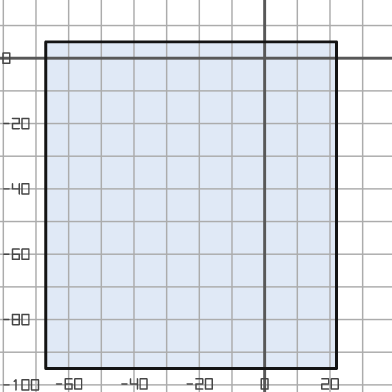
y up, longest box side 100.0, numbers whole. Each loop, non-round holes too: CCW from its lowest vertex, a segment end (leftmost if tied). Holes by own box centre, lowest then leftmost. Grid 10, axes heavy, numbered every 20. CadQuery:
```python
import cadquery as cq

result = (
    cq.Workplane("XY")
    .moveTo(-67.0, -95.0)
    .lineTo(22.0, -95.0)
    .lineTo(22.0, 5.0)
    .lineTo(-67.0, 5.0)
    .close()
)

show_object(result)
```